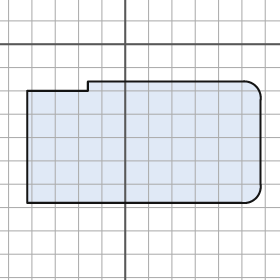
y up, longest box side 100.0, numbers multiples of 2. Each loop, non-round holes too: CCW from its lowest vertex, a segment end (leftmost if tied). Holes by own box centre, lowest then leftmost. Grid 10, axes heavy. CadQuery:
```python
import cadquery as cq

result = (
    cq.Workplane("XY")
    .moveTo(-42.0, -68.0)
    .lineTo(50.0, -68.0)
    .threePointArc((56.0, -66.0), (58.0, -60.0))
    .lineTo(58.0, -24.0)
    .threePointArc((56.0, -18.0), (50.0, -16.0))
    .lineTo(-16.0, -16.0)
    .lineTo(-16.0, -20.0)
    .lineTo(-42.0, -20.0)
    .close()
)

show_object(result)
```